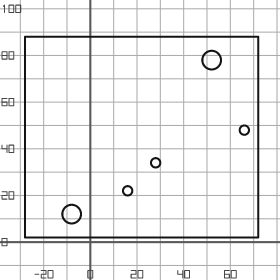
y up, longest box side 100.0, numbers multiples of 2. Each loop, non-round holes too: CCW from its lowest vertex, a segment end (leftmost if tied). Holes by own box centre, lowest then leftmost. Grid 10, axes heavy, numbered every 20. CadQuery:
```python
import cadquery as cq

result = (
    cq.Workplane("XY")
    .moveTo(-28.0, 2.0)
    .lineTo(72.0, 2.0)
    .lineTo(72.0, 88.0)
    .lineTo(-28.0, 88.0)
    .close()
    .moveTo(-8.0, 12.0)
    .circle(4.0)
    .moveTo(16.0, 22.0)
    .circle(2.0)
    .moveTo(28.0, 34.0)
    .circle(2.0)
    .moveTo(66.0, 48.0)
    .circle(2.0)
    .moveTo(52.0, 78.0)
    .circle(4.0)
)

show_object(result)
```